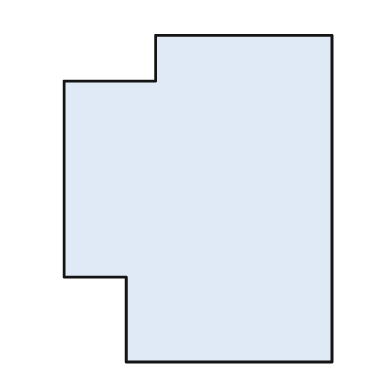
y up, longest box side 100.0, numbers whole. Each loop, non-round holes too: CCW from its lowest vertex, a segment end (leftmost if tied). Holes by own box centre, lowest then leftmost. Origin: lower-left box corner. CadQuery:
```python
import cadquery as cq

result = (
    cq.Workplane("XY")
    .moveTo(19.0, 0.0)
    .lineTo(82.0, 0.0)
    .lineTo(82.0, 100.0)
    .lineTo(28.0, 100.0)
    .lineTo(28.0, 86.0)
    .lineTo(0.0, 86.0)
    .lineTo(0.0, 26.0)
    .lineTo(19.0, 26.0)
    .close()
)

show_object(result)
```